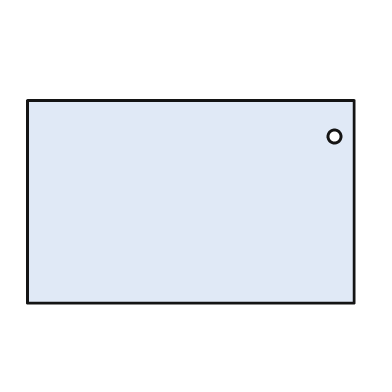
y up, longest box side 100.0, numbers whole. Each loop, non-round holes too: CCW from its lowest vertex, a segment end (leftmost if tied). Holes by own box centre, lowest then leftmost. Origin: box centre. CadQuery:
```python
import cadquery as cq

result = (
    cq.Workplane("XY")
    .moveTo(-50.0, -31.0)
    .lineTo(50.0, -31.0)
    .lineTo(50.0, 31.0)
    .lineTo(-50.0, 31.0)
    .close()
    .moveTo(44.0, 20.0)
    .circle(2.0)
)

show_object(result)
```